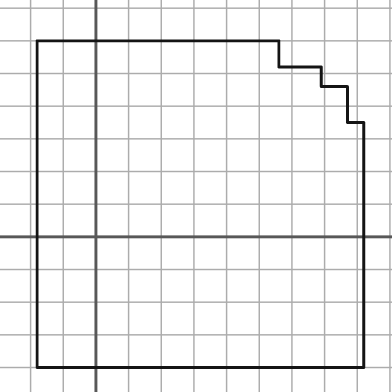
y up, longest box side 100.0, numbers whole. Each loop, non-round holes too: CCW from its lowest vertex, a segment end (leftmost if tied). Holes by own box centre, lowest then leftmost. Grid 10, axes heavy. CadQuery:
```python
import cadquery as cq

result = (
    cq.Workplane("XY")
    .moveTo(-18.0, -40.0)
    .lineTo(82.0, -40.0)
    .lineTo(82.0, 35.0)
    .lineTo(77.0, 35.0)
    .lineTo(77.0, 46.0)
    .lineTo(69.0, 46.0)
    .lineTo(69.0, 52.0)
    .lineTo(56.0, 52.0)
    .lineTo(56.0, 60.0)
    .lineTo(-18.0, 60.0)
    .close()
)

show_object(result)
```